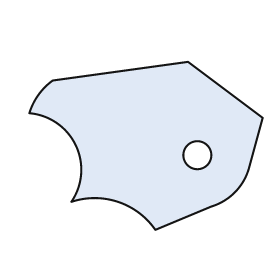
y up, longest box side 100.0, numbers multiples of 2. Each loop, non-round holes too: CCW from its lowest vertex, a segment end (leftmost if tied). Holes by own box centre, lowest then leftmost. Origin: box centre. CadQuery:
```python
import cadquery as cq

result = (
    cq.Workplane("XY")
    .moveTo(4.0, -36.0)
    .lineTo(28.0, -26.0)
    .threePointArc((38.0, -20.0), (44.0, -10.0))
    .lineTo(50.0, 12.0)
    .lineTo(18.0, 36.0)
    .lineTo(-40.0, 28.0)
    .threePointArc((-46.0, 22.0), (-50.0, 14.0))
    .threePointArc((-30.0, 0.0), (-32.0, -24.0))
    .threePointArc((-12.0, -24.0), (4.0, -36.0))
    .close()
    .moveTo(22.0, -4.0)
    .circle(6.0)
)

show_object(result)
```